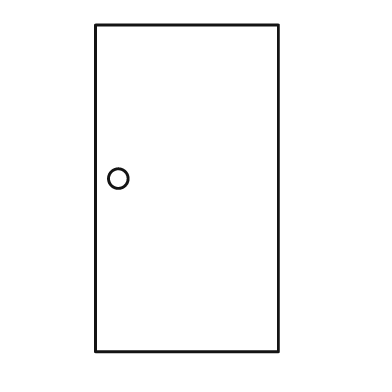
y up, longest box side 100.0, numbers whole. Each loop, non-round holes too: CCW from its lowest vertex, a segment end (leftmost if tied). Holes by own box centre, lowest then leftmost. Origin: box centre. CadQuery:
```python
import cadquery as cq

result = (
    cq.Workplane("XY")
    .moveTo(-28.0, -50.0)
    .lineTo(28.0, -50.0)
    .lineTo(28.0, 50.0)
    .lineTo(-28.0, 50.0)
    .close()
    .moveTo(-21.0, 3.0)
    .circle(3.0)
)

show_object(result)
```